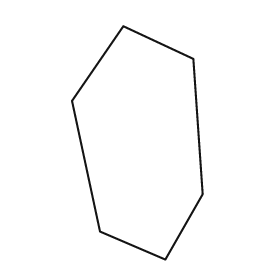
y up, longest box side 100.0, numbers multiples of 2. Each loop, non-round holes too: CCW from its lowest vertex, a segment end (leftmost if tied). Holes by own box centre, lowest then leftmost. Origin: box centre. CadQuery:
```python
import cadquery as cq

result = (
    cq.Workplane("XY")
    .moveTo(12.0, -50.0)
    .lineTo(28.0, -22.0)
    .lineTo(24.0, 36.0)
    .lineTo(-6.0, 50.0)
    .lineTo(-28.0, 18.0)
    .lineTo(-16.0, -38.0)
    .close()
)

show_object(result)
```